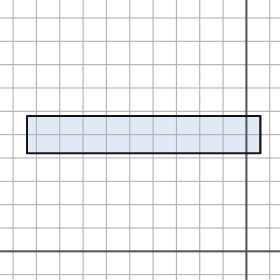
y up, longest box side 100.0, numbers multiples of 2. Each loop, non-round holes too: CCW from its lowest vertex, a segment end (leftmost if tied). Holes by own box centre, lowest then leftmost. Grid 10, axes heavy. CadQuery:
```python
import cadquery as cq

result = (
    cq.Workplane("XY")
    .moveTo(-94.0, 42.0)
    .lineTo(6.0, 42.0)
    .lineTo(6.0, 58.0)
    .lineTo(-94.0, 58.0)
    .close()
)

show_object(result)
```